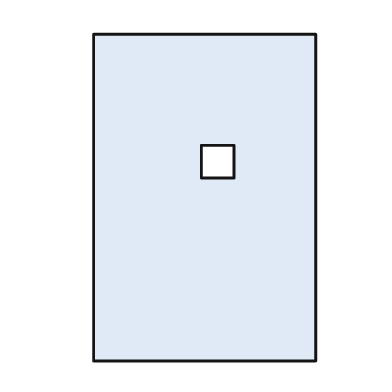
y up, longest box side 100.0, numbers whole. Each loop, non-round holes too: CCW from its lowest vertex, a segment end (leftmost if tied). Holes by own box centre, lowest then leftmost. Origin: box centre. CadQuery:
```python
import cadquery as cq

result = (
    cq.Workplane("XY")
    .moveTo(-34.0, -50.0)
    .lineTo(34.0, -50.0)
    .lineTo(34.0, 50.0)
    .lineTo(-34.0, 50.0)
    .close()
    .moveTo(-1.0, 6.0)
    .lineTo(9.0, 6.0)
    .lineTo(9.0, 16.0)
    .lineTo(-1.0, 16.0)
    .close()
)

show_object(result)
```